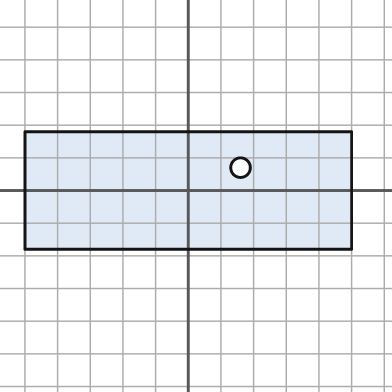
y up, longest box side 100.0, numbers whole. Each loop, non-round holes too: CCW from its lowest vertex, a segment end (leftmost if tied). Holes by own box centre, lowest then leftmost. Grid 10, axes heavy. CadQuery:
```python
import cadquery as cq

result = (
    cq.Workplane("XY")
    .moveTo(-50.0, -18.0)
    .lineTo(50.0, -18.0)
    .lineTo(50.0, 18.0)
    .lineTo(-50.0, 18.0)
    .close()
    .moveTo(16.0, 7.0)
    .circle(3.0)
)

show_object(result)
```